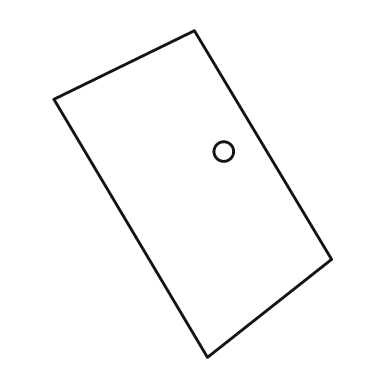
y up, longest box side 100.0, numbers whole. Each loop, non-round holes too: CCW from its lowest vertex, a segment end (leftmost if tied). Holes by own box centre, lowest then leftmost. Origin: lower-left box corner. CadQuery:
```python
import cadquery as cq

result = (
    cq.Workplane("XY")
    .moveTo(47.0, 0.0)
    .lineTo(85.0, 30.0)
    .lineTo(43.0, 100.0)
    .lineTo(0.0, 79.0)
    .close()
    .moveTo(52.0, 63.0)
    .circle(3.0)
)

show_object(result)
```